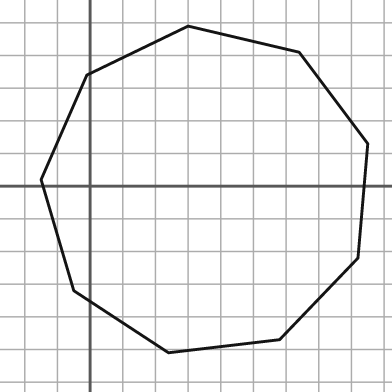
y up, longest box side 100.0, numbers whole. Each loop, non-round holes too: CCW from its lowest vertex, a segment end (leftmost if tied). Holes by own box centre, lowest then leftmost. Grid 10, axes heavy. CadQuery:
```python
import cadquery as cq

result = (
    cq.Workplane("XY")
    .moveTo(24.0, -51.0)
    .lineTo(58.0, -47.0)
    .lineTo(82.0, -22.0)
    .lineTo(85.0, 13.0)
    .lineTo(64.0, 41.0)
    .lineTo(30.0, 49.0)
    .lineTo(-1.0, 34.0)
    .lineTo(-15.0, 2.0)
    .lineTo(-5.0, -32.0)
    .close()
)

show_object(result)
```